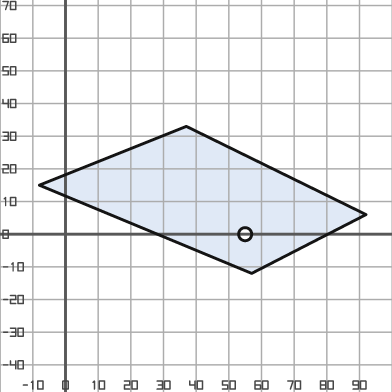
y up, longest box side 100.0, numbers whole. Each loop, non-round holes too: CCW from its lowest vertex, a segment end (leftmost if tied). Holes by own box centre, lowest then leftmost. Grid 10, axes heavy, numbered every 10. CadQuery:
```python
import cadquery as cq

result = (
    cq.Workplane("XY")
    .moveTo(57.0, -12.0)
    .lineTo(92.0, 6.0)
    .lineTo(37.0, 33.0)
    .lineTo(-8.0, 15.0)
    .close()
    .moveTo(55.0, 0.0)
    .circle(2.0)
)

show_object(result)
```